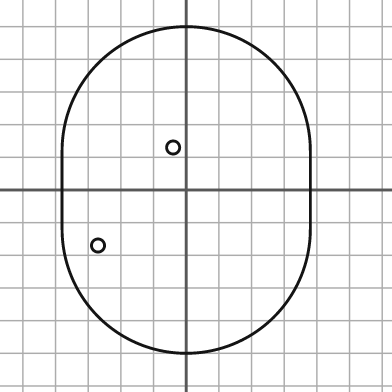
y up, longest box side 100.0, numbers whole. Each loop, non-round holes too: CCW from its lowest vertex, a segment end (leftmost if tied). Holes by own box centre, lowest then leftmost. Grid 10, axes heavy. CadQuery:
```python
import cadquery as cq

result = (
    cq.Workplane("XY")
    .moveTo(-38.0, -12.0)
    .threePointArc((0.0, -50.0), (38.0, -12.0))
    .lineTo(38.0, 12.0)
    .threePointArc((0.0, 50.0), (-38.0, 12.0))
    .close()
    .moveTo(-27.0, -17.0)
    .circle(2.0)
    .moveTo(-4.0, 13.0)
    .circle(2.0)
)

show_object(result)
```